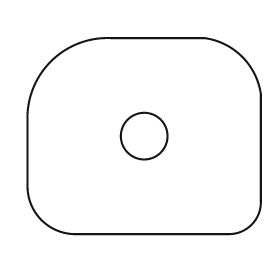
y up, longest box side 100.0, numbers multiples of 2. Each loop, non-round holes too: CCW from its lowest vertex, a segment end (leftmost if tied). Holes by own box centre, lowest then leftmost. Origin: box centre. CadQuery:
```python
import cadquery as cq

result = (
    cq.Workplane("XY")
    .moveTo(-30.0, -42.0)
    .lineTo(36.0, -42.0)
    .threePointArc((46.0, -38.0), (50.0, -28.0))
    .lineTo(50.0, 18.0)
    .threePointArc((42.0, 34.0), (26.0, 42.0))
    .lineTo(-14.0, 42.0)
    .threePointArc((-40.0, 32.0), (-50.0, 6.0))
    .lineTo(-50.0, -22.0)
    .threePointArc((-44.0, -36.0), (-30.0, -42.0))
    .close()
    .moveTo(0.0, 0.0)
    .circle(10.0)
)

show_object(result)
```